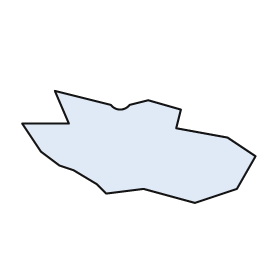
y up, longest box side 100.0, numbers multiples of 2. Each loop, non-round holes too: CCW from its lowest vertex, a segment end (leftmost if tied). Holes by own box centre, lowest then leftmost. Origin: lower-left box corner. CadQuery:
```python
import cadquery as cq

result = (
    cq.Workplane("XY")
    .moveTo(74.0, 0.0)
    .lineTo(92.0, 6.0)
    .lineTo(100.0, 20.0)
    .lineTo(88.0, 28.0)
    .lineTo(66.0, 32.0)
    .lineTo(68.0, 40.0)
    .lineTo(54.0, 44.0)
    .lineTo(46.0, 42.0)
    .threePointArc((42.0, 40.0), (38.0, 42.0))
    .lineTo(14.0, 48.0)
    .lineTo(20.0, 34.0)
    .lineTo(0.0, 34.0)
    .lineTo(8.0, 22.0)
    .lineTo(16.0, 16.0)
    .lineTo(22.0, 14.0)
    .lineTo(32.0, 8.0)
    .lineTo(36.0, 4.0)
    .lineTo(52.0, 6.0)
    .close()
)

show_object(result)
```